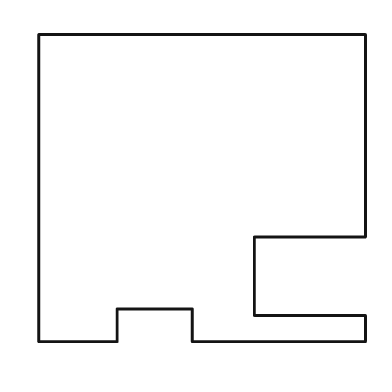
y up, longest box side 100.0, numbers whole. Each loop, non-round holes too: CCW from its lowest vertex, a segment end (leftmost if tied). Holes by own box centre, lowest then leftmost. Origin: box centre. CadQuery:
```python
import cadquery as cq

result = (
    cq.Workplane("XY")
    .moveTo(-50.0, -47.0)
    .lineTo(-26.0, -47.0)
    .lineTo(-26.0, -37.0)
    .lineTo(-3.0, -37.0)
    .lineTo(-3.0, -47.0)
    .lineTo(50.0, -47.0)
    .lineTo(50.0, -39.0)
    .lineTo(16.0, -39.0)
    .lineTo(16.0, -15.0)
    .lineTo(50.0, -15.0)
    .lineTo(50.0, 47.0)
    .lineTo(-50.0, 47.0)
    .close()
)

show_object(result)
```